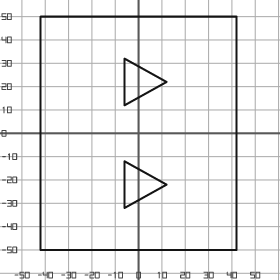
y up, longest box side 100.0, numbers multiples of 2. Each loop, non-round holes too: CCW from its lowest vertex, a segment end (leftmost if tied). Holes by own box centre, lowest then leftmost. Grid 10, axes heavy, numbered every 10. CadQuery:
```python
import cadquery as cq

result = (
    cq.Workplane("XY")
    .moveTo(-42.0, -50.0)
    .lineTo(42.0, -50.0)
    .lineTo(42.0, 50.0)
    .lineTo(-42.0, 50.0)
    .close()
    .moveTo(-6.0, -32.0)
    .lineTo(12.0, -22.0)
    .lineTo(-6.0, -12.0)
    .close()
    .moveTo(-6.0, 12.0)
    .lineTo(12.0, 22.0)
    .lineTo(-6.0, 32.0)
    .close()
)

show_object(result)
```